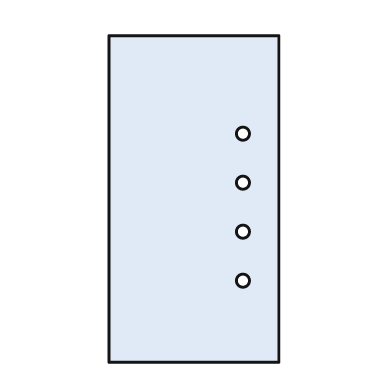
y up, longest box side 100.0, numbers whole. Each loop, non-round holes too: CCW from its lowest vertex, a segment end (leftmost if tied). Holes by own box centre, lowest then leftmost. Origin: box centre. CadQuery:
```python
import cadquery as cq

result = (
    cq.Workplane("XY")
    .moveTo(-26.0, -50.0)
    .lineTo(26.0, -50.0)
    .lineTo(26.0, 50.0)
    .lineTo(-26.0, 50.0)
    .close()
    .moveTo(15.0, -25.0)
    .circle(2.0)
    .moveTo(15.0, -10.0)
    .circle(2.0)
    .moveTo(15.0, 5.0)
    .circle(2.0)
    .moveTo(15.0, 20.0)
    .circle(2.0)
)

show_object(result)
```